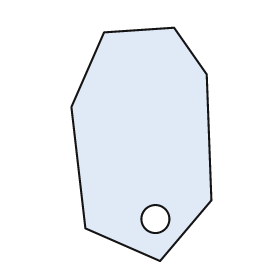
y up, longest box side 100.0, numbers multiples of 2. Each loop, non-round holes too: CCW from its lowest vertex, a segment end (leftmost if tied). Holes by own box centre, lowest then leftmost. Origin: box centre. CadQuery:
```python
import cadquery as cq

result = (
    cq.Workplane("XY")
    .moveTo(8.0, -50.0)
    .lineTo(30.0, -24.0)
    .lineTo(28.0, 30.0)
    .lineTo(14.0, 50.0)
    .lineTo(-16.0, 48.0)
    .lineTo(-30.0, 16.0)
    .lineTo(-24.0, -36.0)
    .close()
    .moveTo(6.0, -32.0)
    .circle(6.0)
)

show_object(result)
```